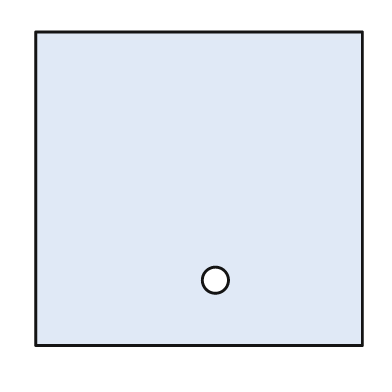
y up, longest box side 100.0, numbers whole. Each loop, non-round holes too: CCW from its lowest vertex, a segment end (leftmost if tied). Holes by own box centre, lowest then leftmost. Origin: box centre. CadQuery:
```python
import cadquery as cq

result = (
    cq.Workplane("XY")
    .moveTo(-50.0, -48.0)
    .lineTo(50.0, -48.0)
    .lineTo(50.0, 48.0)
    .lineTo(-50.0, 48.0)
    .close()
    .moveTo(5.0, -28.0)
    .circle(4.0)
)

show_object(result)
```